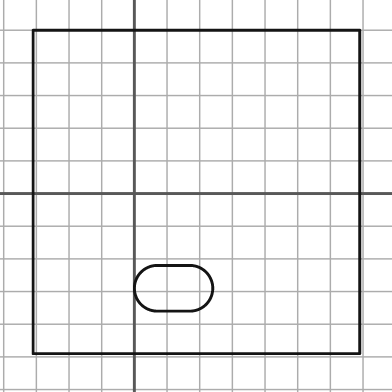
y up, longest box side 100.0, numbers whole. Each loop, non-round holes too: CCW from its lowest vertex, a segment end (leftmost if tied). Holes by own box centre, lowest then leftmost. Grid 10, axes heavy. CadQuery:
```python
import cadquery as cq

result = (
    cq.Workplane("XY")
    .moveTo(-31.0, -49.0)
    .lineTo(69.0, -49.0)
    .lineTo(69.0, 50.0)
    .lineTo(-31.0, 50.0)
    .close()
    .moveTo(7.0, -36.0)
    .lineTo(17.0, -36.0)
    .threePointArc((24.0, -29.0), (17.0, -22.0))
    .lineTo(7.0, -22.0)
    .threePointArc((0.0, -29.0), (7.0, -36.0))
    .close()
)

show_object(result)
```